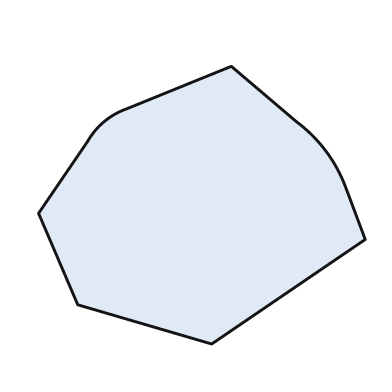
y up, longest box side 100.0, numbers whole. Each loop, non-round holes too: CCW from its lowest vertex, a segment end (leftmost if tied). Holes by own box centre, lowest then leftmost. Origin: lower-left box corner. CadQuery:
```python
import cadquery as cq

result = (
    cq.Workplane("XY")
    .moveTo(53.0, 0.0)
    .lineTo(100.0, 32.0)
    .lineTo(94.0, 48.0)
    .threePointArc((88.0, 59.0), (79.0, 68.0))
    .lineTo(59.0, 85.0)
    .lineTo(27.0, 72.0)
    .threePointArc((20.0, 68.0), (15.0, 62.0))
    .lineTo(0.0, 40.0)
    .lineTo(12.0, 12.0)
    .close()
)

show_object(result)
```